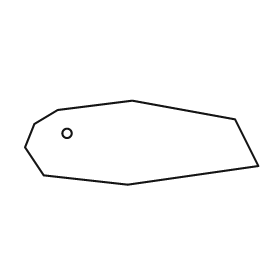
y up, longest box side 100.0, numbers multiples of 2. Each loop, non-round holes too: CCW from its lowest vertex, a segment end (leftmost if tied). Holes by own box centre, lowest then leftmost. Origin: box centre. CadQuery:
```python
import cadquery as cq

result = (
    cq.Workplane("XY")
    .moveTo(-6.0, -18.0)
    .lineTo(50.0, -10.0)
    .lineTo(40.0, 10.0)
    .lineTo(-4.0, 18.0)
    .lineTo(-36.0, 14.0)
    .lineTo(-46.0, 8.0)
    .lineTo(-50.0, -2.0)
    .lineTo(-42.0, -14.0)
    .close()
    .moveTo(-32.0, 4.0)
    .circle(2.0)
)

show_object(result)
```